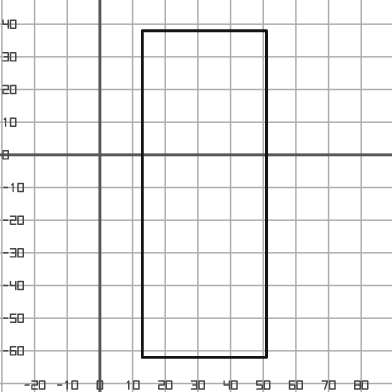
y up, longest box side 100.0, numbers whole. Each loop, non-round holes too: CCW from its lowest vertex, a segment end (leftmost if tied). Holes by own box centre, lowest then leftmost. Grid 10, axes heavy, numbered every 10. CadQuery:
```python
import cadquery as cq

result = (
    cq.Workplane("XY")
    .moveTo(13.0, -62.0)
    .lineTo(51.0, -62.0)
    .lineTo(51.0, 38.0)
    .lineTo(13.0, 38.0)
    .close()
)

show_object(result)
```